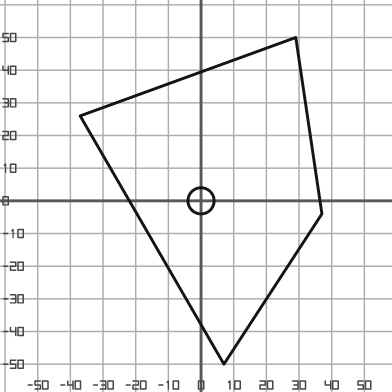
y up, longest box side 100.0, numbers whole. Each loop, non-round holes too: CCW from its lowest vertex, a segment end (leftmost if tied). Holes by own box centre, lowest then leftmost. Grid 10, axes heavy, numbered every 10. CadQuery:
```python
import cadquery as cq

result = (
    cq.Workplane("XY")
    .moveTo(7.0, -50.0)
    .lineTo(37.0, -4.0)
    .lineTo(29.0, 50.0)
    .lineTo(-37.0, 26.0)
    .close()
    .moveTo(0.0, 0.0)
    .circle(4.0)
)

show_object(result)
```